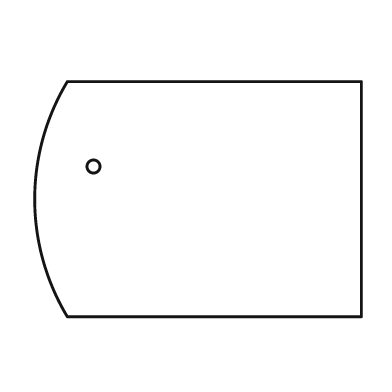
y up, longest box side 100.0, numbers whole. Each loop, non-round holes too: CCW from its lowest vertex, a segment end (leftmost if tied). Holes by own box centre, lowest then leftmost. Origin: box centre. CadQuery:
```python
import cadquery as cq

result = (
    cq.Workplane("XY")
    .moveTo(-40.0, -36.0)
    .lineTo(50.0, -36.0)
    .lineTo(50.0, 36.0)
    .lineTo(-40.0, 36.0)
    .threePointArc((-50.0, 0.0), (-40.0, -36.0))
    .close()
    .moveTo(-32.0, 10.0)
    .circle(2.0)
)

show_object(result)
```